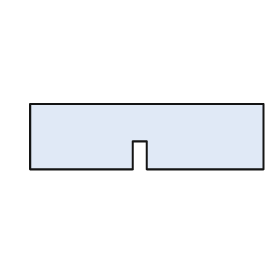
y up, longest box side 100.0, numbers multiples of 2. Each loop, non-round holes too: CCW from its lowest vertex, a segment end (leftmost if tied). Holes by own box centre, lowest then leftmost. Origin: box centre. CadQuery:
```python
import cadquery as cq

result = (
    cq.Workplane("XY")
    .moveTo(-50.0, -14.0)
    .lineTo(-6.0, -14.0)
    .lineTo(-6.0, -2.0)
    .lineTo(0.0, -2.0)
    .lineTo(0.0, -14.0)
    .lineTo(50.0, -14.0)
    .lineTo(50.0, 14.0)
    .lineTo(-50.0, 14.0)
    .close()
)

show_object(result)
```